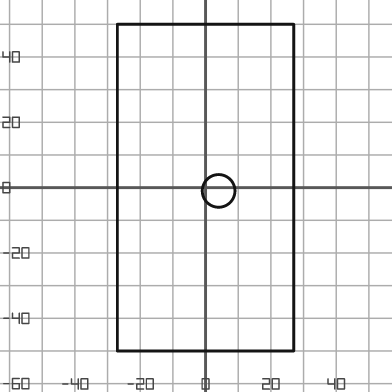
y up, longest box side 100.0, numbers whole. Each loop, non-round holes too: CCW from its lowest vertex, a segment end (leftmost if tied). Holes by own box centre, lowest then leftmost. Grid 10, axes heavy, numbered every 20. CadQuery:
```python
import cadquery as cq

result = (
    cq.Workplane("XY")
    .moveTo(-27.0, -50.0)
    .lineTo(27.0, -50.0)
    .lineTo(27.0, 50.0)
    .lineTo(-27.0, 50.0)
    .close()
    .moveTo(4.0, -1.0)
    .circle(5.0)
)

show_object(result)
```